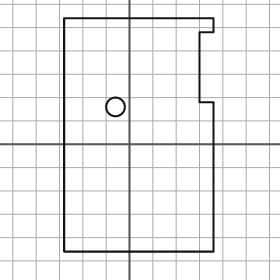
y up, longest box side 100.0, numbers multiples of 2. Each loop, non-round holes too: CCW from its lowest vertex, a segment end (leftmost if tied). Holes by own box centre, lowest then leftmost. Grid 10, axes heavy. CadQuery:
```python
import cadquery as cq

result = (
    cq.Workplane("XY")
    .moveTo(-28.0, -46.0)
    .lineTo(36.0, -46.0)
    .lineTo(36.0, 18.0)
    .lineTo(30.0, 18.0)
    .lineTo(30.0, 48.0)
    .lineTo(36.0, 48.0)
    .lineTo(36.0, 54.0)
    .lineTo(-28.0, 54.0)
    .close()
    .moveTo(-6.0, 16.0)
    .circle(4.0)
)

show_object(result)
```